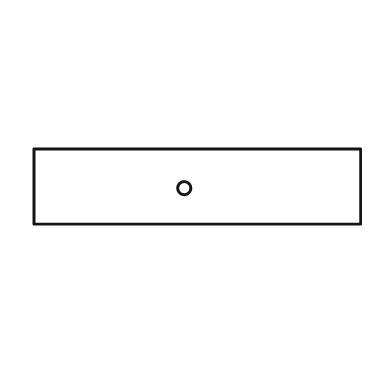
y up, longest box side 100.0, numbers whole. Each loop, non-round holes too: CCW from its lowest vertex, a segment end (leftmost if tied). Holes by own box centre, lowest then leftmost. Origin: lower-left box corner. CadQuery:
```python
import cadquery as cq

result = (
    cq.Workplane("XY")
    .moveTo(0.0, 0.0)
    .lineTo(100.0, 0.0)
    .lineTo(100.0, 23.0)
    .lineTo(0.0, 23.0)
    .close()
    .moveTo(46.0, 11.0)
    .circle(2.0)
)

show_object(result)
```